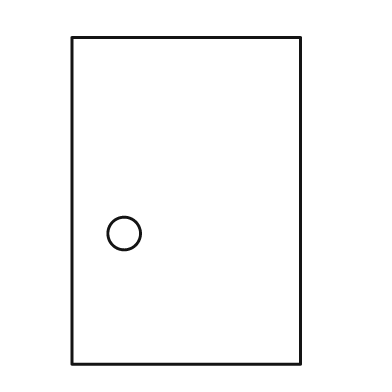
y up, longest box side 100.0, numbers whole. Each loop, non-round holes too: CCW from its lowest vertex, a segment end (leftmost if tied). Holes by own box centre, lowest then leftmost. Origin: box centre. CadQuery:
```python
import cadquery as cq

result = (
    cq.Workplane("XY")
    .moveTo(-35.0, -50.0)
    .lineTo(35.0, -50.0)
    .lineTo(35.0, 50.0)
    .lineTo(-35.0, 50.0)
    .close()
    .moveTo(-19.0, -10.0)
    .circle(5.0)
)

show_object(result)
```